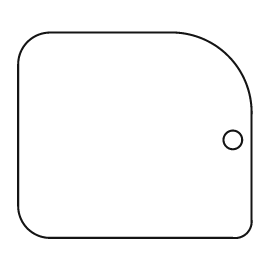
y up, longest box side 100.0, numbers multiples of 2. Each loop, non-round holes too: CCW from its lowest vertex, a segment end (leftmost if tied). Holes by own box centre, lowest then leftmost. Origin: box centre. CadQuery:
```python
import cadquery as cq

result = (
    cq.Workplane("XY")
    .moveTo(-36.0, -44.0)
    .lineTo(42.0, -44.0)
    .threePointArc((48.0, -42.0), (50.0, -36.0))
    .lineTo(50.0, 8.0)
    .threePointArc((40.0, 34.0), (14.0, 44.0))
    .lineTo(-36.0, 44.0)
    .threePointArc((-46.0, 40.0), (-50.0, 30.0))
    .lineTo(-50.0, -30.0)
    .threePointArc((-46.0, -40.0), (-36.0, -44.0))
    .close()
    .moveTo(42.0, -2.0)
    .circle(4.0)
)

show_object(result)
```